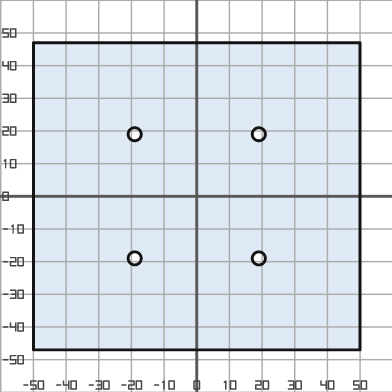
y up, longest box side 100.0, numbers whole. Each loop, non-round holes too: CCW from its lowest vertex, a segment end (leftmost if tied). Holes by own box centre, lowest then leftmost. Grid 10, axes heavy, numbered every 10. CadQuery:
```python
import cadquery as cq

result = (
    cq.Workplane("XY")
    .moveTo(-50.0, -47.0)
    .lineTo(50.0, -47.0)
    .lineTo(50.0, 47.0)
    .lineTo(-50.0, 47.0)
    .close()
    .moveTo(-19.0, -19.0)
    .circle(2.0)
    .moveTo(19.0, -19.0)
    .circle(2.0)
    .moveTo(-19.0, 19.0)
    .circle(2.0)
    .moveTo(19.0, 19.0)
    .circle(2.0)
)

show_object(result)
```